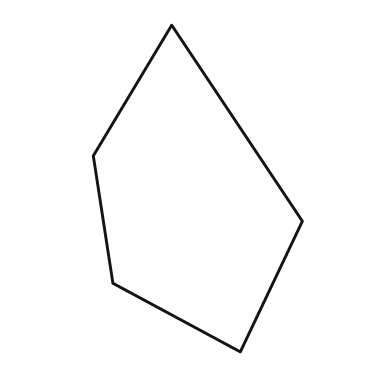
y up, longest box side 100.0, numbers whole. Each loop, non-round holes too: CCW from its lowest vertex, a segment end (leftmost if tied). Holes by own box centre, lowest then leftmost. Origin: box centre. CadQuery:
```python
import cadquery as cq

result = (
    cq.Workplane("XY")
    .moveTo(13.0, -50.0)
    .lineTo(32.0, -10.0)
    .lineTo(-8.0, 50.0)
    .lineTo(-32.0, 10.0)
    .lineTo(-26.0, -29.0)
    .close()
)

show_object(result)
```